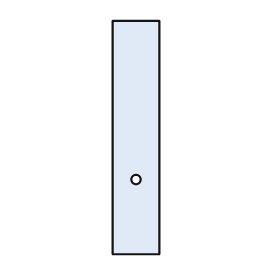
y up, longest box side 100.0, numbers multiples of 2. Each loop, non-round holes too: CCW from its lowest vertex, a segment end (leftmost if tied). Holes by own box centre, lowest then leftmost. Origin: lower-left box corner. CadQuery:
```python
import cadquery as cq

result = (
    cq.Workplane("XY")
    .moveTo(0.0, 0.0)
    .lineTo(20.0, 0.0)
    .lineTo(20.0, 100.0)
    .lineTo(0.0, 100.0)
    .close()
    .moveTo(10.0, 32.0)
    .circle(2.0)
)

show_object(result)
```